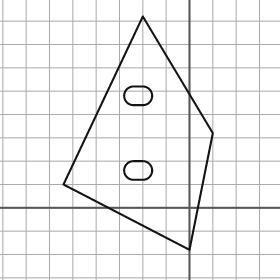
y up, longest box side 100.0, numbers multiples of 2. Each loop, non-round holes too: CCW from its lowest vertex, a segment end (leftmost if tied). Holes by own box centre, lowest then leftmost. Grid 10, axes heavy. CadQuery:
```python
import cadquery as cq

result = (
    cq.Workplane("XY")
    .moveTo(0.0, -18.0)
    .lineTo(10.0, 32.0)
    .lineTo(-20.0, 82.0)
    .lineTo(-54.0, 10.0)
    .close()
    .moveTo(-24.0, 12.0)
    .lineTo(-20.0, 12.0)
    .threePointArc((-16.0, 16.0), (-20.0, 20.0))
    .lineTo(-24.0, 20.0)
    .threePointArc((-28.0, 16.0), (-24.0, 12.0))
    .close()
    .moveTo(-24.0, 44.0)
    .lineTo(-20.0, 44.0)
    .threePointArc((-16.0, 48.0), (-20.0, 52.0))
    .lineTo(-24.0, 52.0)
    .threePointArc((-28.0, 48.0), (-24.0, 44.0))
    .close()
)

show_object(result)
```